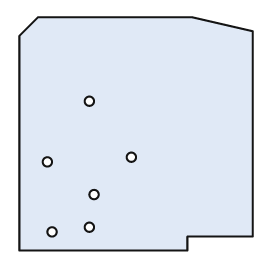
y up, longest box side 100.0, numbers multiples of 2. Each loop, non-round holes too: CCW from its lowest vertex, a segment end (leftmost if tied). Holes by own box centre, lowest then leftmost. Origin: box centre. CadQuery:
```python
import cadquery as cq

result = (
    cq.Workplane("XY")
    .moveTo(-50.0, -50.0)
    .lineTo(22.0, -50.0)
    .lineTo(22.0, -44.0)
    .lineTo(50.0, -44.0)
    .lineTo(50.0, 44.0)
    .lineTo(24.0, 50.0)
    .lineTo(-42.0, 50.0)
    .lineTo(-50.0, 42.0)
    .close()
    .moveTo(-36.0, -42.0)
    .circle(2.0)
    .moveTo(-20.0, -40.0)
    .circle(2.0)
    .moveTo(-18.0, -26.0)
    .circle(2.0)
    .moveTo(-38.0, -12.0)
    .circle(2.0)
    .moveTo(-2.0, -10.0)
    .circle(2.0)
    .moveTo(-20.0, 14.0)
    .circle(2.0)
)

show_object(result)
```